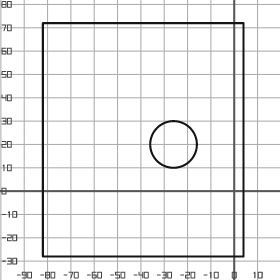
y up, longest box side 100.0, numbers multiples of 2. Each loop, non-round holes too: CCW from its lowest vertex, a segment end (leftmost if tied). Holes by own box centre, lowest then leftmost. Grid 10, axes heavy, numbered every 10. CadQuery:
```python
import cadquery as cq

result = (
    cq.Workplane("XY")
    .moveTo(-82.0, -28.0)
    .lineTo(4.0, -28.0)
    .lineTo(4.0, 72.0)
    .lineTo(-82.0, 72.0)
    .close()
    .moveTo(-26.0, 20.0)
    .circle(10.0)
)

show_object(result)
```